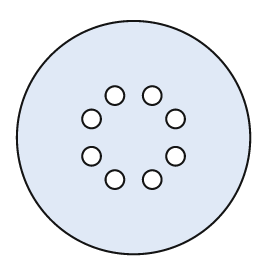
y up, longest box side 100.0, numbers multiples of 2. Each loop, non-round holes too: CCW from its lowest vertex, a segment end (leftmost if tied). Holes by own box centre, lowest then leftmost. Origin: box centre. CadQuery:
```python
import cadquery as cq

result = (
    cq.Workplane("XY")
    .moveTo(0.0, 0.0)
    .circle(50.0)
    .moveTo(-8.0, -18.0)
    .circle(4.0)
    .moveTo(8.0, -18.0)
    .circle(4.0)
    .moveTo(-18.0, -8.0)
    .circle(4.0)
    .moveTo(18.0, -8.0)
    .circle(4.0)
    .moveTo(-18.0, 8.0)
    .circle(4.0)
    .moveTo(18.0, 8.0)
    .circle(4.0)
    .moveTo(-8.0, 18.0)
    .circle(4.0)
    .moveTo(8.0, 18.0)
    .circle(4.0)
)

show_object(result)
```